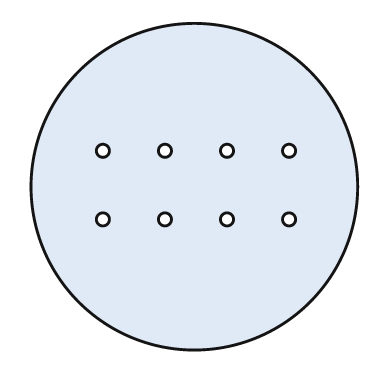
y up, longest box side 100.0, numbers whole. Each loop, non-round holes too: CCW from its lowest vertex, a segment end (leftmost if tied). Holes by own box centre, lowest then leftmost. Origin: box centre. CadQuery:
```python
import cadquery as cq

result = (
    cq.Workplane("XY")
    .moveTo(0.0, 0.0)
    .circle(50.0)
    .moveTo(-28.0, -10.0)
    .circle(2.0)
    .moveTo(-9.0, -10.0)
    .circle(2.0)
    .moveTo(10.0, -10.0)
    .circle(2.0)
    .moveTo(29.0, -10.0)
    .circle(2.0)
    .moveTo(-28.0, 11.0)
    .circle(2.0)
    .moveTo(-9.0, 11.0)
    .circle(2.0)
    .moveTo(10.0, 11.0)
    .circle(2.0)
    .moveTo(29.0, 11.0)
    .circle(2.0)
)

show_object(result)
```